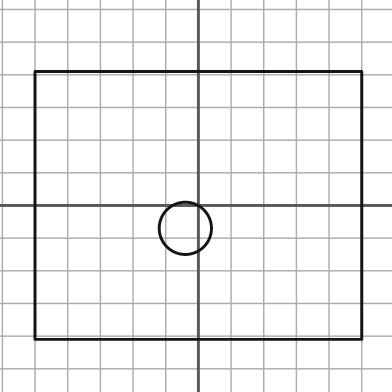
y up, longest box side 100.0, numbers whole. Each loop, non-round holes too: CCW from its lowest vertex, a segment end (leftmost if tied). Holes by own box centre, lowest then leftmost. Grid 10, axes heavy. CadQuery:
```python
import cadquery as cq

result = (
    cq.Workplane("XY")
    .moveTo(-50.0, -41.0)
    .lineTo(50.0, -41.0)
    .lineTo(50.0, 41.0)
    .lineTo(-50.0, 41.0)
    .close()
    .moveTo(-4.0, -7.0)
    .circle(8.0)
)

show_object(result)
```